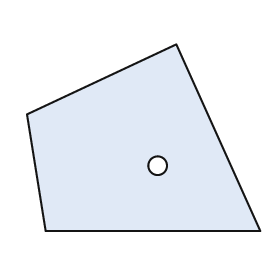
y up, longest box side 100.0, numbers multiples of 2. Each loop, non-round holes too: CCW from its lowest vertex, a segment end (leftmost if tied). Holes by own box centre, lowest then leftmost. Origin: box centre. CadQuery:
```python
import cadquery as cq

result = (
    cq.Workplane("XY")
    .moveTo(-42.0, -40.0)
    .lineTo(50.0, -40.0)
    .lineTo(14.0, 40.0)
    .lineTo(-50.0, 10.0)
    .close()
    .moveTo(6.0, -12.0)
    .circle(4.0)
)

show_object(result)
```